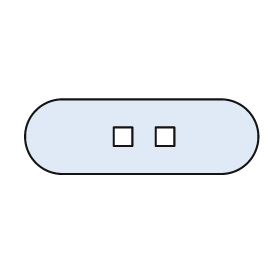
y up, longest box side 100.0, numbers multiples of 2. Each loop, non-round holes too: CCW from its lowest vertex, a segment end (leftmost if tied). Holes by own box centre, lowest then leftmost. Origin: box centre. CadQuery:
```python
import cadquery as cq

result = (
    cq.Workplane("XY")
    .moveTo(-34.0, -16.0)
    .lineTo(34.0, -16.0)
    .threePointArc((50.0, 0.0), (34.0, 16.0))
    .lineTo(-34.0, 16.0)
    .threePointArc((-50.0, 0.0), (-34.0, -16.0))
    .close()
    .moveTo(-12.0, -4.0)
    .lineTo(-4.0, -4.0)
    .lineTo(-4.0, 4.0)
    .lineTo(-12.0, 4.0)
    .close()
    .moveTo(6.0, -4.0)
    .lineTo(14.0, -4.0)
    .lineTo(14.0, 4.0)
    .lineTo(6.0, 4.0)
    .close()
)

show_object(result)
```